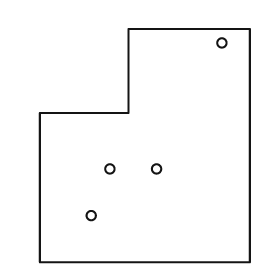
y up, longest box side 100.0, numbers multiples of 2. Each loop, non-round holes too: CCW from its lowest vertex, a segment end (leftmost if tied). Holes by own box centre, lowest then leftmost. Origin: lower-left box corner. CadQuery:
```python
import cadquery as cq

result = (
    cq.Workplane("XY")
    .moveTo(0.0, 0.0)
    .lineTo(90.0, 0.0)
    .lineTo(90.0, 100.0)
    .lineTo(38.0, 100.0)
    .lineTo(38.0, 64.0)
    .lineTo(0.0, 64.0)
    .close()
    .moveTo(22.0, 20.0)
    .circle(2.0)
    .moveTo(30.0, 40.0)
    .circle(2.0)
    .moveTo(50.0, 40.0)
    .circle(2.0)
    .moveTo(78.0, 94.0)
    .circle(2.0)
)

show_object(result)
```